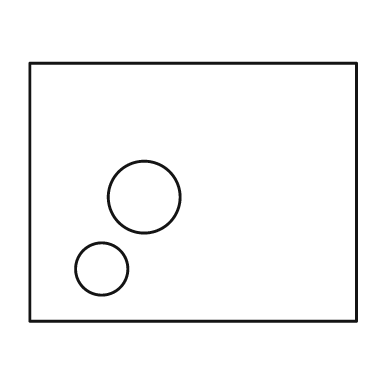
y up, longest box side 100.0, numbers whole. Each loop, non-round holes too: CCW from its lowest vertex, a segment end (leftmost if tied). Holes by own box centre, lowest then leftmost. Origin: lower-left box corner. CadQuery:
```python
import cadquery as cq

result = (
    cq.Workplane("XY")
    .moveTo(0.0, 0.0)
    .lineTo(100.0, 0.0)
    .lineTo(100.0, 79.0)
    .lineTo(0.0, 79.0)
    .close()
    .moveTo(22.0, 16.0)
    .circle(8.0)
    .moveTo(35.0, 38.0)
    .circle(11.0)
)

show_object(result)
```